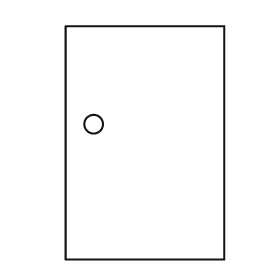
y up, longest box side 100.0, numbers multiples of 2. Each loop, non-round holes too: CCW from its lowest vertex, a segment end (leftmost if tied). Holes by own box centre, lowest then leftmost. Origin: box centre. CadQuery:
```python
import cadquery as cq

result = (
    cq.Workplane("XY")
    .moveTo(-34.0, -50.0)
    .lineTo(34.0, -50.0)
    .lineTo(34.0, 50.0)
    .lineTo(-34.0, 50.0)
    .close()
    .moveTo(-22.0, 8.0)
    .circle(4.0)
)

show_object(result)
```